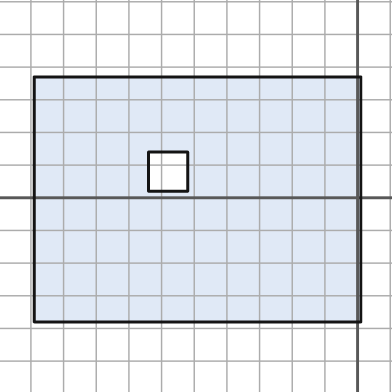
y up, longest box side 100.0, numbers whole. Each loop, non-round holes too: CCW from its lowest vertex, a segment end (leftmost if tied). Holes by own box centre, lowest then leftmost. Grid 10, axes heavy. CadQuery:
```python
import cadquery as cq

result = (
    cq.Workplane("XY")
    .moveTo(-99.0, -38.0)
    .lineTo(1.0, -38.0)
    .lineTo(1.0, 37.0)
    .lineTo(-99.0, 37.0)
    .close()
    .moveTo(-64.0, 2.0)
    .lineTo(-52.0, 2.0)
    .lineTo(-52.0, 14.0)
    .lineTo(-64.0, 14.0)
    .close()
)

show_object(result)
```